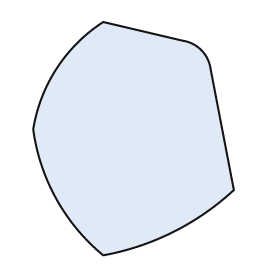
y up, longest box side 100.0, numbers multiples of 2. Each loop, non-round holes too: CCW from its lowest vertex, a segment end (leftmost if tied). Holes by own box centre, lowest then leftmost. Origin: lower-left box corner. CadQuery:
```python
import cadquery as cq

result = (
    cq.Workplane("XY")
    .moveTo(30.0, 0.0)
    .threePointArc((60.0, 10.0), (86.0, 28.0))
    .lineTo(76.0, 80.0)
    .threePointArc((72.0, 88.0), (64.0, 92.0))
    .lineTo(30.0, 100.0)
    .threePointArc((10.0, 80.0), (0.0, 54.0))
    .threePointArc((10.0, 24.0), (30.0, 0.0))
    .close()
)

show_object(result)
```